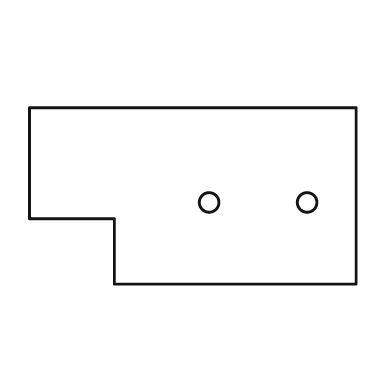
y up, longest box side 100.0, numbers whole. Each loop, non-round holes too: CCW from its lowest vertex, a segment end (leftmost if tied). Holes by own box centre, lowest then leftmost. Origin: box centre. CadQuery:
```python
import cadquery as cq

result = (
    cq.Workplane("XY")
    .moveTo(-24.0, -27.0)
    .lineTo(50.0, -27.0)
    .lineTo(50.0, 27.0)
    .lineTo(-50.0, 27.0)
    .lineTo(-50.0, -7.0)
    .lineTo(-24.0, -7.0)
    .close()
    .moveTo(5.0, -2.0)
    .circle(3.0)
    .moveTo(35.0, -2.0)
    .circle(3.0)
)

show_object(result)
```